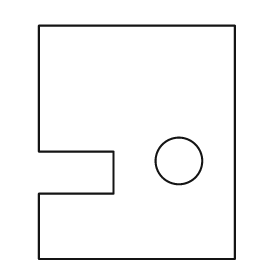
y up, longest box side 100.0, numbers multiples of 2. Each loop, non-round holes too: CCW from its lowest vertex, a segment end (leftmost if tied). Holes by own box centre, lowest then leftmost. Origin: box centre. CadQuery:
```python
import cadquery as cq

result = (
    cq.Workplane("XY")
    .moveTo(-42.0, -50.0)
    .lineTo(42.0, -50.0)
    .lineTo(42.0, 50.0)
    .lineTo(-42.0, 50.0)
    .lineTo(-42.0, -4.0)
    .lineTo(-10.0, -4.0)
    .lineTo(-10.0, -22.0)
    .lineTo(-42.0, -22.0)
    .close()
    .moveTo(18.0, -8.0)
    .circle(10.0)
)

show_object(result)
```